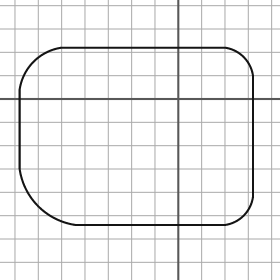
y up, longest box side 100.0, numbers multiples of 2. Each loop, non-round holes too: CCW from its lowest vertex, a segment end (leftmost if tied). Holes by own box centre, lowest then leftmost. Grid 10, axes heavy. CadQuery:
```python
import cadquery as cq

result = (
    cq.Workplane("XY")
    .moveTo(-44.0, -54.0)
    .lineTo(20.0, -54.0)
    .threePointArc((28.0, -50.0), (32.0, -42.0))
    .lineTo(32.0, 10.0)
    .threePointArc((28.0, 18.0), (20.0, 22.0))
    .lineTo(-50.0, 22.0)
    .threePointArc((-62.0, 16.0), (-68.0, 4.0))
    .lineTo(-68.0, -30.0)
    .threePointArc((-60.0, -46.0), (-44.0, -54.0))
    .close()
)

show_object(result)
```